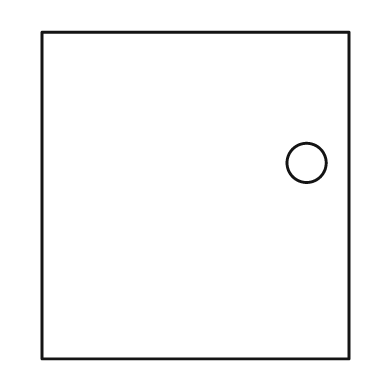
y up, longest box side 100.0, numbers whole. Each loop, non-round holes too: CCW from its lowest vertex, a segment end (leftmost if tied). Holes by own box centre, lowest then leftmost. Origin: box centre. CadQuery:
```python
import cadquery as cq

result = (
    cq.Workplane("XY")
    .moveTo(-47.0, -50.0)
    .lineTo(47.0, -50.0)
    .lineTo(47.0, 50.0)
    .lineTo(-47.0, 50.0)
    .close()
    .moveTo(34.0, 10.0)
    .circle(6.0)
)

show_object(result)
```